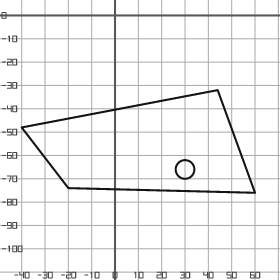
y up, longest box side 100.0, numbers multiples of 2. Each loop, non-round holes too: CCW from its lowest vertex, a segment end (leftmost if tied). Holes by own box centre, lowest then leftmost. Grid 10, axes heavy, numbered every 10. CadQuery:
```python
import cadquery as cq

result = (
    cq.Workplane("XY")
    .moveTo(60.0, -76.0)
    .lineTo(44.0, -32.0)
    .lineTo(-40.0, -48.0)
    .lineTo(-20.0, -74.0)
    .close()
    .moveTo(30.0, -66.0)
    .circle(4.0)
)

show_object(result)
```